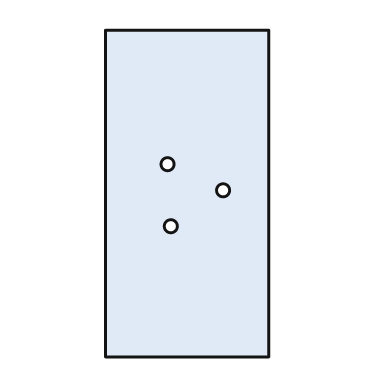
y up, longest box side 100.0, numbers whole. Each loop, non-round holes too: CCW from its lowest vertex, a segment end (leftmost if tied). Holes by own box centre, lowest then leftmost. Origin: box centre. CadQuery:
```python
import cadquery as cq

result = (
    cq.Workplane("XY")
    .moveTo(-25.0, -50.0)
    .lineTo(25.0, -50.0)
    .lineTo(25.0, 50.0)
    .lineTo(-25.0, 50.0)
    .close()
    .moveTo(-5.0, -10.0)
    .circle(2.0)
    .moveTo(11.0, 1.0)
    .circle(2.0)
    .moveTo(-6.0, 9.0)
    .circle(2.0)
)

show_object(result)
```